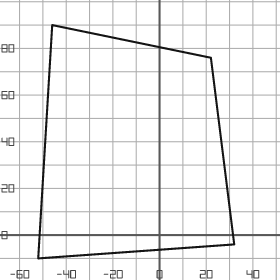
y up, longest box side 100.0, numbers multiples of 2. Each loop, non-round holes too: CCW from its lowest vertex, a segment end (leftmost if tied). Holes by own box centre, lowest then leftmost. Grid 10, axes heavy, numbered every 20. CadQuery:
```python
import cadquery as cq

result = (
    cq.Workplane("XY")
    .moveTo(-52.0, -10.0)
    .lineTo(32.0, -4.0)
    .lineTo(22.0, 76.0)
    .lineTo(-46.0, 90.0)
    .close()
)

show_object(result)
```